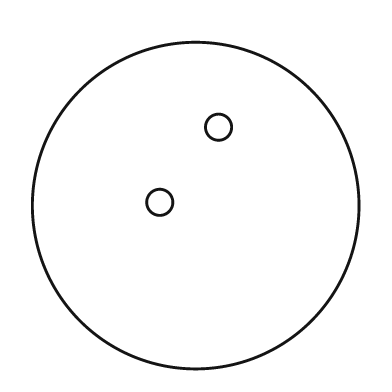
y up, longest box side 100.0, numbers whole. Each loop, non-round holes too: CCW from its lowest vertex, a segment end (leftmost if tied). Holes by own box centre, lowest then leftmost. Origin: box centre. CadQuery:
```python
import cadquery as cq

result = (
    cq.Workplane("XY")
    .moveTo(0.0, 0.0)
    .circle(50.0)
    .moveTo(-11.0, 1.0)
    .circle(4.0)
    .moveTo(7.0, 24.0)
    .circle(4.0)
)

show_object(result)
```